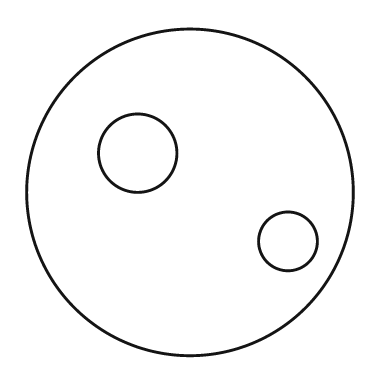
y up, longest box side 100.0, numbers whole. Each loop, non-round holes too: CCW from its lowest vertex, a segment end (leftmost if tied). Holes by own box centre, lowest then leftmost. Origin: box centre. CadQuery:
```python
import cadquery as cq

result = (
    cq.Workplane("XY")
    .moveTo(0.0, 0.0)
    .circle(50.0)
    .moveTo(30.0, -15.0)
    .circle(9.0)
    .moveTo(-16.0, 12.0)
    .circle(12.0)
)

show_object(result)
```